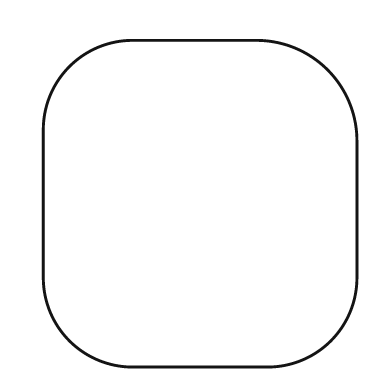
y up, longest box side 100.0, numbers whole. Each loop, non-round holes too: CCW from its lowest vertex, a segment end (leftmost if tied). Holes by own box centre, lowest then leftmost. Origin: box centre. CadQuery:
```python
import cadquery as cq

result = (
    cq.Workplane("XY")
    .moveTo(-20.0, -50.0)
    .lineTo(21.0, -50.0)
    .threePointArc((40.0, -42.0), (48.0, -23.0))
    .lineTo(48.0, 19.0)
    .threePointArc((39.0, 41.0), (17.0, 50.0))
    .lineTo(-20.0, 50.0)
    .threePointArc((-40.0, 42.0), (-48.0, 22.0))
    .lineTo(-48.0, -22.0)
    .threePointArc((-40.0, -42.0), (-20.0, -50.0))
    .close()
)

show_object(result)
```